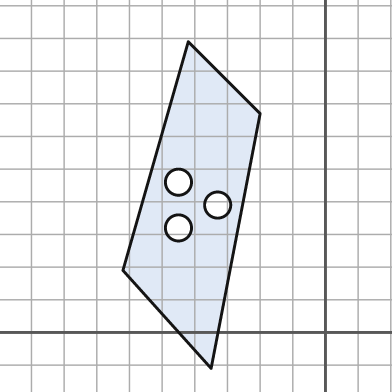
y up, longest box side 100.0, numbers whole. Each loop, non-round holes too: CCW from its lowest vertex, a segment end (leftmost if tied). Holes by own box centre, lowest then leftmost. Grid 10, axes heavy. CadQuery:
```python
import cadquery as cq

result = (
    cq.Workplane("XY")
    .moveTo(-35.0, -11.0)
    .lineTo(-20.0, 67.0)
    .lineTo(-42.0, 89.0)
    .lineTo(-62.0, 19.0)
    .close()
    .moveTo(-45.0, 32.0)
    .circle(4.0)
    .moveTo(-33.0, 39.0)
    .circle(4.0)
    .moveTo(-45.0, 46.0)
    .circle(4.0)
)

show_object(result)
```